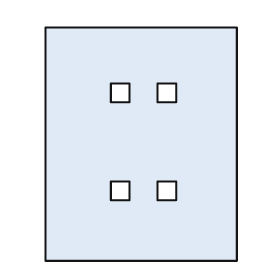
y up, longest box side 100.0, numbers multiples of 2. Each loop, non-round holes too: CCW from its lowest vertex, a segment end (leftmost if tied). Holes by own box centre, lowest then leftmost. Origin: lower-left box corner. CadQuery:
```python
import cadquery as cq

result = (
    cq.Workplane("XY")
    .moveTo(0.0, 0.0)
    .lineTo(82.0, 0.0)
    .lineTo(82.0, 100.0)
    .lineTo(0.0, 100.0)
    .close()
    .moveTo(28.0, 26.0)
    .lineTo(36.0, 26.0)
    .lineTo(36.0, 34.0)
    .lineTo(28.0, 34.0)
    .close()
    .moveTo(48.0, 26.0)
    .lineTo(56.0, 26.0)
    .lineTo(56.0, 34.0)
    .lineTo(48.0, 34.0)
    .close()
    .moveTo(28.0, 68.0)
    .lineTo(36.0, 68.0)
    .lineTo(36.0, 76.0)
    .lineTo(28.0, 76.0)
    .close()
    .moveTo(48.0, 68.0)
    .lineTo(56.0, 68.0)
    .lineTo(56.0, 76.0)
    .lineTo(48.0, 76.0)
    .close()
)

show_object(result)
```